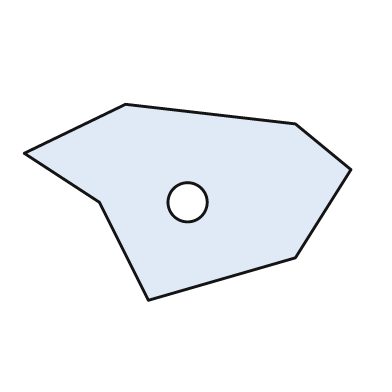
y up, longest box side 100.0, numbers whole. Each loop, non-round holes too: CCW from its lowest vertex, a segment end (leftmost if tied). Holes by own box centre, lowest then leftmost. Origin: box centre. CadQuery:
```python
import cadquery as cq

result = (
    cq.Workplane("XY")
    .moveTo(-12.0, -30.0)
    .lineTo(33.0, -17.0)
    .lineTo(50.0, 10.0)
    .lineTo(33.0, 24.0)
    .lineTo(-19.0, 30.0)
    .lineTo(-50.0, 15.0)
    .lineTo(-27.0, 0.0)
    .close()
    .moveTo(0.0, 0.0)
    .circle(6.0)
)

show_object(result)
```